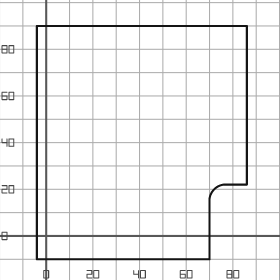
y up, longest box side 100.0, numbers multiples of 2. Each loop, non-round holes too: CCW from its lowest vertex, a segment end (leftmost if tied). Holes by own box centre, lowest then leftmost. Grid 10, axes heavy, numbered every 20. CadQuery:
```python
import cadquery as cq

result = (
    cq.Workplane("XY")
    .moveTo(-4.0, -10.0)
    .lineTo(70.0, -10.0)
    .lineTo(70.0, 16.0)
    .threePointArc((72.0, 20.0), (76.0, 22.0))
    .lineTo(86.0, 22.0)
    .lineTo(86.0, 90.0)
    .lineTo(-4.0, 90.0)
    .close()
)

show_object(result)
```